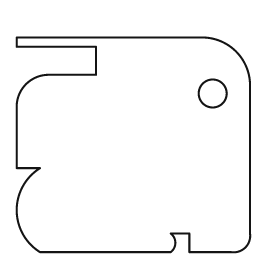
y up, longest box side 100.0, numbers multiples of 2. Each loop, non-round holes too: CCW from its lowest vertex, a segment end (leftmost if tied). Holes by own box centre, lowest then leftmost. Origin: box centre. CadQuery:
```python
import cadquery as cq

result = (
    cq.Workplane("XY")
    .moveTo(-40.0, -46.0)
    .lineTo(16.0, -46.0)
    .threePointArc((18.0, -42.0), (16.0, -38.0))
    .lineTo(24.0, -38.0)
    .lineTo(24.0, -46.0)
    .lineTo(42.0, -46.0)
    .threePointArc((48.0, -44.0), (50.0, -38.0))
    .lineTo(50.0, 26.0)
    .threePointArc((44.0, 40.0), (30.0, 46.0))
    .lineTo(-50.0, 46.0)
    .lineTo(-50.0, 42.0)
    .lineTo(-16.0, 42.0)
    .lineTo(-16.0, 30.0)
    .lineTo(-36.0, 30.0)
    .threePointArc((-46.0, 26.0), (-50.0, 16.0))
    .lineTo(-50.0, -10.0)
    .lineTo(-40.0, -10.0)
    .threePointArc((-50.0, -28.0), (-40.0, -46.0))
    .close()
    .moveTo(34.0, 22.0)
    .circle(6.0)
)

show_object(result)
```